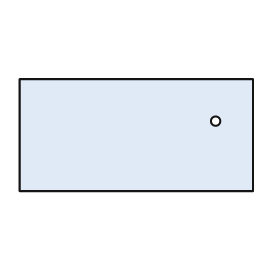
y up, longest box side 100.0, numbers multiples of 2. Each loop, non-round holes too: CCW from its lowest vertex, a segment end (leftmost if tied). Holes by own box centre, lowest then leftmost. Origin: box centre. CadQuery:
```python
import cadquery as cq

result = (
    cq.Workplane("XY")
    .moveTo(-50.0, -24.0)
    .lineTo(50.0, -24.0)
    .lineTo(50.0, 24.0)
    .lineTo(-50.0, 24.0)
    .close()
    .moveTo(34.0, 6.0)
    .circle(2.0)
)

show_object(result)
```